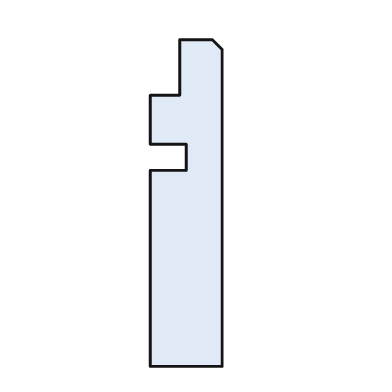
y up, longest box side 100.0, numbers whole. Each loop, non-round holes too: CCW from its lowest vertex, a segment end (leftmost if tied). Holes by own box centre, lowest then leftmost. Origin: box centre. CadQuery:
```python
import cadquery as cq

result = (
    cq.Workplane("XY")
    .moveTo(-11.0, -50.0)
    .lineTo(11.0, -50.0)
    .lineTo(11.0, 47.0)
    .lineTo(8.0, 50.0)
    .lineTo(-2.0, 50.0)
    .lineTo(-2.0, 33.0)
    .lineTo(-11.0, 33.0)
    .lineTo(-11.0, 18.0)
    .lineTo(0.0, 18.0)
    .lineTo(0.0, 10.0)
    .lineTo(-11.0, 10.0)
    .close()
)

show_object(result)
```